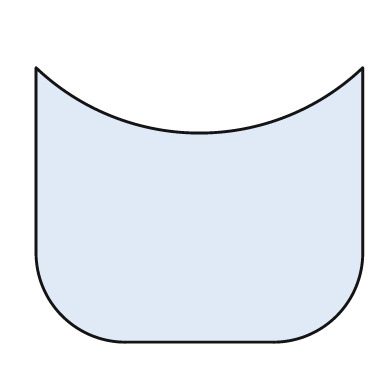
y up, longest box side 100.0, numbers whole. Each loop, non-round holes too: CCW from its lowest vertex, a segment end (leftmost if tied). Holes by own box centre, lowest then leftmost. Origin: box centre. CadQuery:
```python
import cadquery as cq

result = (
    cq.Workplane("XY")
    .moveTo(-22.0, -42.0)
    .lineTo(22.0, -42.0)
    .threePointArc((42.0, -34.0), (50.0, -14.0))
    .lineTo(50.0, 42.0)
    .threePointArc((0.0, 22.0), (-50.0, 42.0))
    .lineTo(-50.0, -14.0)
    .threePointArc((-42.0, -34.0), (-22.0, -42.0))
    .close()
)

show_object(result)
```